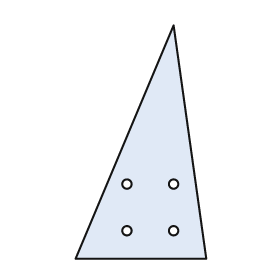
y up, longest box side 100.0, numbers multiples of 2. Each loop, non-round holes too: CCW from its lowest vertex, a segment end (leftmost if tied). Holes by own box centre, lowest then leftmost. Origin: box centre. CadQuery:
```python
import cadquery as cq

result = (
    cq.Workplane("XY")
    .moveTo(-28.0, -50.0)
    .lineTo(28.0, -50.0)
    .lineTo(14.0, 50.0)
    .close()
    .moveTo(-6.0, -38.0)
    .circle(2.0)
    .moveTo(14.0, -38.0)
    .circle(2.0)
    .moveTo(-6.0, -18.0)
    .circle(2.0)
    .moveTo(14.0, -18.0)
    .circle(2.0)
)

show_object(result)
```